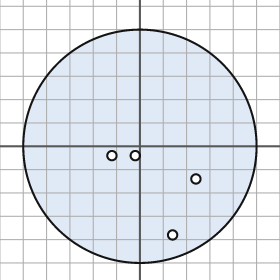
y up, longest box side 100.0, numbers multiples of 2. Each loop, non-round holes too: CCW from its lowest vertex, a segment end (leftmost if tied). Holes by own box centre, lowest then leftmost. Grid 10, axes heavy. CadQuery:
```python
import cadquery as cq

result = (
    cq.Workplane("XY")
    .moveTo(0.0, 0.0)
    .circle(50.0)
    .moveTo(14.0, -38.0)
    .circle(2.0)
    .moveTo(24.0, -14.0)
    .circle(2.0)
    .moveTo(-12.0, -4.0)
    .circle(2.0)
    .moveTo(-2.0, -4.0)
    .circle(2.0)
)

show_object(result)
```